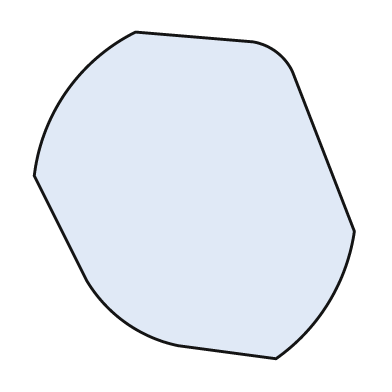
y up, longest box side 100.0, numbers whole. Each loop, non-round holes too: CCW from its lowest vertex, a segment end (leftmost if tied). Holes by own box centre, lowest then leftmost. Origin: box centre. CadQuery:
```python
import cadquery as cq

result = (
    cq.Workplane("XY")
    .moveTo(25.0, -50.0)
    .threePointArc((41.0, -33.0), (49.0, -11.0))
    .lineTo(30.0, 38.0)
    .threePointArc((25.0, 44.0), (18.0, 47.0))
    .lineTo(-18.0, 50.0)
    .threePointArc((-39.0, 32.0), (-49.0, 6.0))
    .lineTo(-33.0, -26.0)
    .threePointArc((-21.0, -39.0), (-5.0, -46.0))
    .close()
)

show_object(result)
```